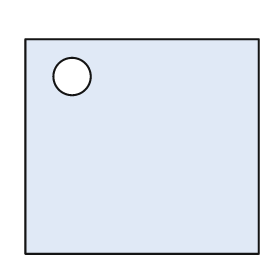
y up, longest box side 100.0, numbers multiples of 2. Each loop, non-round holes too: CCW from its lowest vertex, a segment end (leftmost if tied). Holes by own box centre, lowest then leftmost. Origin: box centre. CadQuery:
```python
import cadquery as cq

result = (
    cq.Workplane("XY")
    .moveTo(-50.0, -46.0)
    .lineTo(50.0, -46.0)
    .lineTo(50.0, 46.0)
    .lineTo(-50.0, 46.0)
    .close()
    .moveTo(-30.0, 30.0)
    .circle(8.0)
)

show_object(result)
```